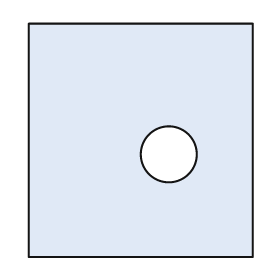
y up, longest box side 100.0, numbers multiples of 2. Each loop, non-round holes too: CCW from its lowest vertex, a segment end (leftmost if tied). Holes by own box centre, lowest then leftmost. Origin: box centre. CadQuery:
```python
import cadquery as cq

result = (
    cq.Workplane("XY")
    .moveTo(-48.0, -50.0)
    .lineTo(48.0, -50.0)
    .lineTo(48.0, 50.0)
    .lineTo(-48.0, 50.0)
    .close()
    .moveTo(12.0, -6.0)
    .circle(12.0)
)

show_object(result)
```